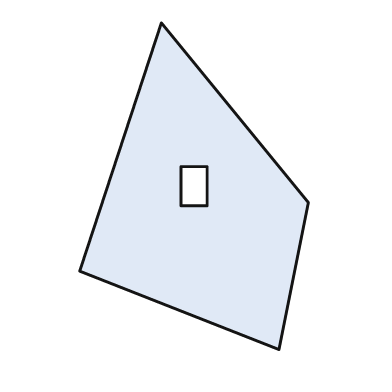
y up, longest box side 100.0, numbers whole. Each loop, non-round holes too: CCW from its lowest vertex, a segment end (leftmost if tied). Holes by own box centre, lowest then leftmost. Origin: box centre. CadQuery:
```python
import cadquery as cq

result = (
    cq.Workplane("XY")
    .moveTo(26.0, -50.0)
    .lineTo(35.0, -5.0)
    .lineTo(-10.0, 50.0)
    .lineTo(-35.0, -26.0)
    .close()
    .moveTo(-4.0, -6.0)
    .lineTo(4.0, -6.0)
    .lineTo(4.0, 6.0)
    .lineTo(-4.0, 6.0)
    .close()
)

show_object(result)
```